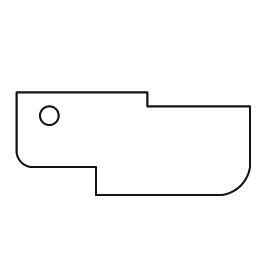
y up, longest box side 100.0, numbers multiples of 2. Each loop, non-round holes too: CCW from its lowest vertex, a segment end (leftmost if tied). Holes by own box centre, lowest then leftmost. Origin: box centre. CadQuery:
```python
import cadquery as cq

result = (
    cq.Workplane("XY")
    .moveTo(-16.0, -22.0)
    .lineTo(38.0, -22.0)
    .threePointArc((46.0, -18.0), (50.0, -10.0))
    .lineTo(50.0, 16.0)
    .lineTo(6.0, 16.0)
    .lineTo(6.0, 22.0)
    .lineTo(-50.0, 22.0)
    .lineTo(-50.0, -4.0)
    .threePointArc((-48.0, -8.0), (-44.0, -10.0))
    .lineTo(-16.0, -10.0)
    .close()
    .moveTo(-36.0, 12.0)
    .circle(4.0)
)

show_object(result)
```